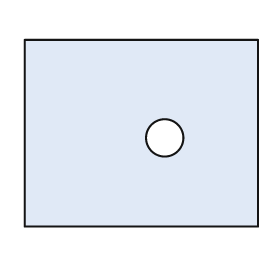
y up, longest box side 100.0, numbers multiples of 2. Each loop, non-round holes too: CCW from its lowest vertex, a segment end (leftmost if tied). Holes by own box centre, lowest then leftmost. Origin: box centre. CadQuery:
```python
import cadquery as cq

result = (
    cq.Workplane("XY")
    .moveTo(-50.0, -40.0)
    .lineTo(50.0, -40.0)
    .lineTo(50.0, 40.0)
    .lineTo(-50.0, 40.0)
    .close()
    .moveTo(10.0, -2.0)
    .circle(8.0)
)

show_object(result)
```